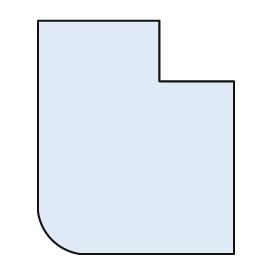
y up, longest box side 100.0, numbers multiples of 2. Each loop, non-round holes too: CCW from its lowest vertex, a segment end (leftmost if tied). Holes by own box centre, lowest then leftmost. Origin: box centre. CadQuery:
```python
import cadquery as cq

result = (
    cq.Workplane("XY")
    .moveTo(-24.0, -50.0)
    .lineTo(42.0, -50.0)
    .lineTo(42.0, 24.0)
    .lineTo(10.0, 24.0)
    .lineTo(10.0, 50.0)
    .lineTo(-42.0, 50.0)
    .lineTo(-42.0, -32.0)
    .threePointArc((-36.0, -44.0), (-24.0, -50.0))
    .close()
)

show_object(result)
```